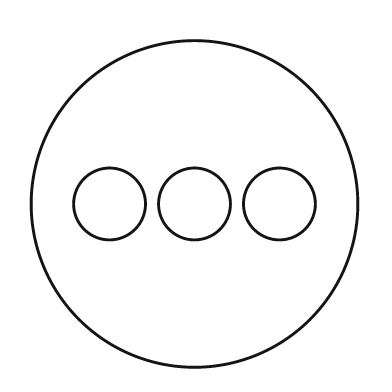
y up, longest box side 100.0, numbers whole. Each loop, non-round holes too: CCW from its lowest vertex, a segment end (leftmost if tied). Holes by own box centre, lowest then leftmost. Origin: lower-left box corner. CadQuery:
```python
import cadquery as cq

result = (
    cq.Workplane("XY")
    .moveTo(50.0, 50.0)
    .circle(50.0)
    .moveTo(24.0, 50.0)
    .circle(11.0)
    .moveTo(50.0, 50.0)
    .circle(11.0)
    .moveTo(76.0, 50.0)
    .circle(11.0)
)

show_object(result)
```